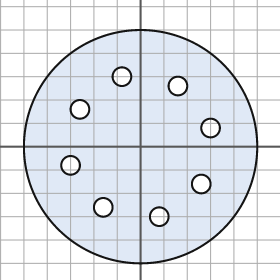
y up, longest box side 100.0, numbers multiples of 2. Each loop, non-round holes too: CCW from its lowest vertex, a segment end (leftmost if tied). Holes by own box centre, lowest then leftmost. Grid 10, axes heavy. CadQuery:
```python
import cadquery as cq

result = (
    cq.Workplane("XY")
    .moveTo(0.0, 0.0)
    .circle(50.0)
    .moveTo(8.0, -30.0)
    .circle(4.0)
    .moveTo(-16.0, -26.0)
    .circle(4.0)
    .moveTo(26.0, -16.0)
    .circle(4.0)
    .moveTo(-30.0, -8.0)
    .circle(4.0)
    .moveTo(30.0, 8.0)
    .circle(4.0)
    .moveTo(-26.0, 16.0)
    .circle(4.0)
    .moveTo(16.0, 26.0)
    .circle(4.0)
    .moveTo(-8.0, 30.0)
    .circle(4.0)
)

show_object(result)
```